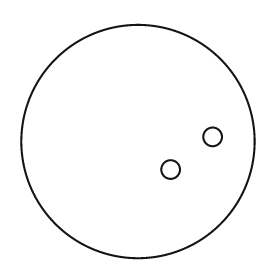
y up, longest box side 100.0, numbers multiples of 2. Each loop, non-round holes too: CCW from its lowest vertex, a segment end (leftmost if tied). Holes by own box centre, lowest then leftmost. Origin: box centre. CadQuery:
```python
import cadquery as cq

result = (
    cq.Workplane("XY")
    .moveTo(0.0, 0.0)
    .circle(50.0)
    .moveTo(14.0, -12.0)
    .circle(4.0)
    .moveTo(32.0, 2.0)
    .circle(4.0)
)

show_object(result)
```